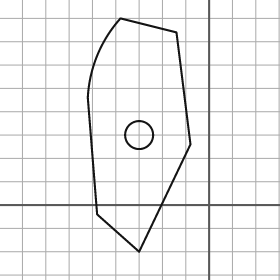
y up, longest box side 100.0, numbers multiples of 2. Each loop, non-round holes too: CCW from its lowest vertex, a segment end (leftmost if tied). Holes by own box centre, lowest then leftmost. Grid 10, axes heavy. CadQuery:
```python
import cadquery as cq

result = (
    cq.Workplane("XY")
    .moveTo(-30.0, -20.0)
    .lineTo(-8.0, 26.0)
    .lineTo(-14.0, 74.0)
    .lineTo(-38.0, 80.0)
    .threePointArc((-48.0, 64.0), (-52.0, 46.0))
    .lineTo(-48.0, -4.0)
    .close()
    .moveTo(-30.0, 30.0)
    .circle(6.0)
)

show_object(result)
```